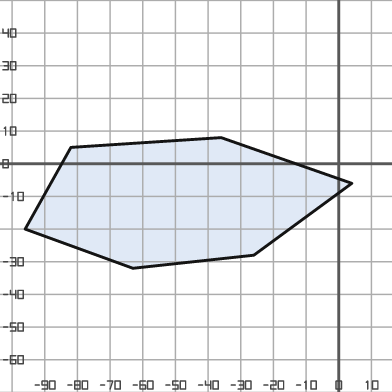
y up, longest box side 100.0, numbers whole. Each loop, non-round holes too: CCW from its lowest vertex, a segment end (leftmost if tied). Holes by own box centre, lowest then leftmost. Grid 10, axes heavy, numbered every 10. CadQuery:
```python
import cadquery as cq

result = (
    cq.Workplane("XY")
    .moveTo(-63.0, -32.0)
    .lineTo(-26.0, -28.0)
    .lineTo(4.0, -6.0)
    .lineTo(-36.0, 8.0)
    .lineTo(-82.0, 5.0)
    .lineTo(-96.0, -20.0)
    .close()
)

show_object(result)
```